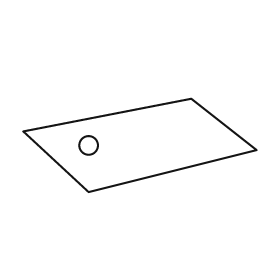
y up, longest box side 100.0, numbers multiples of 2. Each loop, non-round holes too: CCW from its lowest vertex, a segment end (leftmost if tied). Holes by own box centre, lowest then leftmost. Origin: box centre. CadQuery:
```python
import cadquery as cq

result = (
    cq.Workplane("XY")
    .moveTo(-22.0, -20.0)
    .lineTo(50.0, -2.0)
    .lineTo(22.0, 20.0)
    .lineTo(-50.0, 6.0)
    .close()
    .moveTo(-22.0, 0.0)
    .circle(4.0)
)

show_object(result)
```